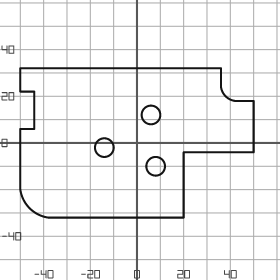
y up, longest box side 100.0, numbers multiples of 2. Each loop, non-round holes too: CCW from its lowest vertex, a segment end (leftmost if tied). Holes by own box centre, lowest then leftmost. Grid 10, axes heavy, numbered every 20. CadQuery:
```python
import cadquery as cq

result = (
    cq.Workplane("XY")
    .moveTo(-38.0, -32.0)
    .lineTo(20.0, -32.0)
    .lineTo(20.0, -4.0)
    .lineTo(50.0, -4.0)
    .lineTo(50.0, 18.0)
    .lineTo(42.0, 18.0)
    .threePointArc((38.0, 20.0), (36.0, 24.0))
    .lineTo(36.0, 32.0)
    .lineTo(-50.0, 32.0)
    .lineTo(-50.0, 22.0)
    .lineTo(-44.0, 22.0)
    .lineTo(-44.0, 6.0)
    .lineTo(-50.0, 6.0)
    .lineTo(-50.0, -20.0)
    .threePointArc((-46.0, -28.0), (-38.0, -32.0))
    .close()
    .moveTo(8.0, -10.0)
    .circle(4.0)
    .moveTo(-14.0, -2.0)
    .circle(4.0)
    .moveTo(6.0, 12.0)
    .circle(4.0)
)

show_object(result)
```